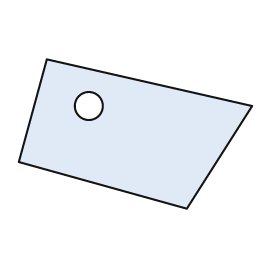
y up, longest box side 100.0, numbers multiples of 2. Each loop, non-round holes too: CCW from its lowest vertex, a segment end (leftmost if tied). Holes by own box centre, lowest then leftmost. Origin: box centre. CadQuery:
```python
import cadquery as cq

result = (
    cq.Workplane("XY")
    .moveTo(22.0, -32.0)
    .lineTo(50.0, 12.0)
    .lineTo(-38.0, 32.0)
    .lineTo(-50.0, -12.0)
    .close()
    .moveTo(-20.0, 12.0)
    .circle(6.0)
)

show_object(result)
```